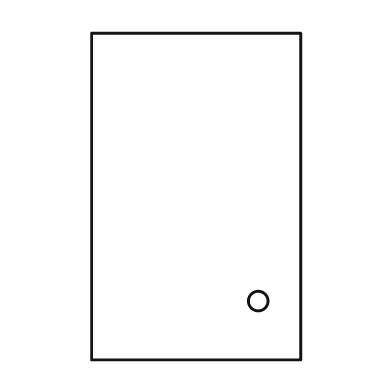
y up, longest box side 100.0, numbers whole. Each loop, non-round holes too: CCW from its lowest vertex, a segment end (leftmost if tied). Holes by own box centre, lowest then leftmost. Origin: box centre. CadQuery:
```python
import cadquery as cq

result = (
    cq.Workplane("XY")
    .moveTo(-32.0, -50.0)
    .lineTo(32.0, -50.0)
    .lineTo(32.0, 50.0)
    .lineTo(-32.0, 50.0)
    .close()
    .moveTo(19.0, -32.0)
    .circle(3.0)
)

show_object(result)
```